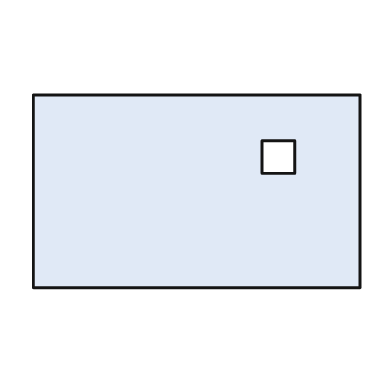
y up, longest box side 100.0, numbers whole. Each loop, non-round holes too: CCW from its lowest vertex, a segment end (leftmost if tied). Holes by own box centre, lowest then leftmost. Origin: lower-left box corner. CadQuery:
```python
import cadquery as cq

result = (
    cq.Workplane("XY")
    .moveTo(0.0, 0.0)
    .lineTo(100.0, 0.0)
    .lineTo(100.0, 59.0)
    .lineTo(0.0, 59.0)
    .close()
    .moveTo(70.0, 35.0)
    .lineTo(80.0, 35.0)
    .lineTo(80.0, 45.0)
    .lineTo(70.0, 45.0)
    .close()
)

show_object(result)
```